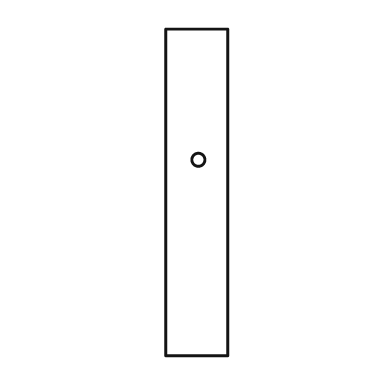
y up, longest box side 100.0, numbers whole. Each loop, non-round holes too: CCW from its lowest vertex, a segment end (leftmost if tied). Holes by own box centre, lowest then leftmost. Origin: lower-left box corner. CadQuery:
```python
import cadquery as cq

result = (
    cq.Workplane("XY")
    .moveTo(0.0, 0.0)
    .lineTo(19.0, 0.0)
    .lineTo(19.0, 100.0)
    .lineTo(0.0, 100.0)
    .close()
    .moveTo(10.0, 60.0)
    .circle(2.0)
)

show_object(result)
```